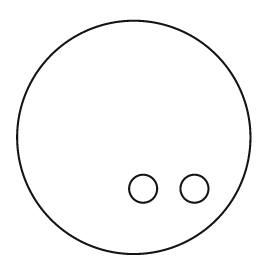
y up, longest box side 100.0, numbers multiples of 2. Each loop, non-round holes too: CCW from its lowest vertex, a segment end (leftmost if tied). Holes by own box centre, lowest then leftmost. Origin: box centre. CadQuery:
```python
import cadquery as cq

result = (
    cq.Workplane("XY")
    .moveTo(0.0, 0.0)
    .circle(50.0)
    .moveTo(4.0, -22.0)
    .circle(6.0)
    .moveTo(26.0, -22.0)
    .circle(6.0)
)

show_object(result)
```